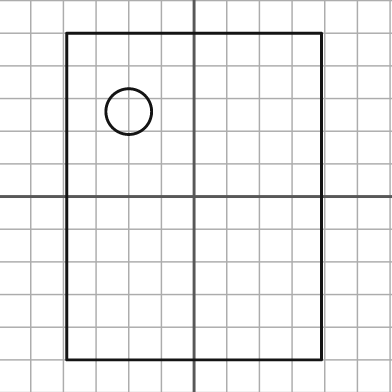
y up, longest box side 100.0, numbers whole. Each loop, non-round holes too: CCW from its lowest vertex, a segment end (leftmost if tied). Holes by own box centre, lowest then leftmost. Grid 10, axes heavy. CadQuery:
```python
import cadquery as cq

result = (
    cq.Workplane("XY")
    .moveTo(-39.0, -50.0)
    .lineTo(39.0, -50.0)
    .lineTo(39.0, 50.0)
    .lineTo(-39.0, 50.0)
    .close()
    .moveTo(-20.0, 26.0)
    .circle(7.0)
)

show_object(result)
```